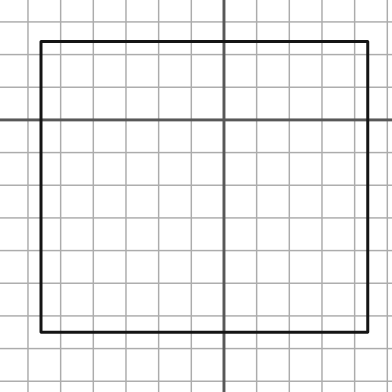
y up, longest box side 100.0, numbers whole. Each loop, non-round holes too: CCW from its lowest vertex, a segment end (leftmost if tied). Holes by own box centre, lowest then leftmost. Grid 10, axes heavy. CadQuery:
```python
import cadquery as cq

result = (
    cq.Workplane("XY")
    .moveTo(-56.0, -65.0)
    .lineTo(44.0, -65.0)
    .lineTo(44.0, 24.0)
    .lineTo(-56.0, 24.0)
    .close()
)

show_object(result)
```